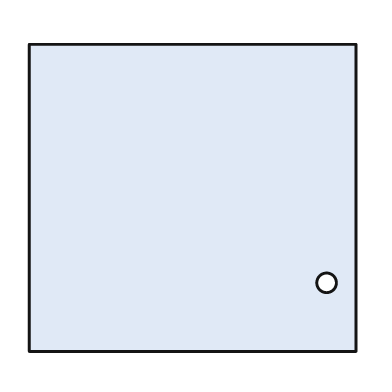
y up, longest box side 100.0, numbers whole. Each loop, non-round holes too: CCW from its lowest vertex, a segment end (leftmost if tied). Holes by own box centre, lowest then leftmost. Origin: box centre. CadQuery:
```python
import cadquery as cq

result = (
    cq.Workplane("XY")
    .moveTo(-50.0, -47.0)
    .lineTo(50.0, -47.0)
    .lineTo(50.0, 47.0)
    .lineTo(-50.0, 47.0)
    .close()
    .moveTo(41.0, -26.0)
    .circle(3.0)
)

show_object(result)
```